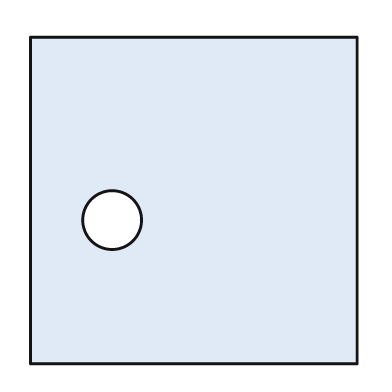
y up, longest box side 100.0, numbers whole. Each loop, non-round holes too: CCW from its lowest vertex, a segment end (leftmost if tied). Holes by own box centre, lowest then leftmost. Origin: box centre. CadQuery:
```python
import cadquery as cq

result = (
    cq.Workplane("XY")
    .moveTo(-50.0, -50.0)
    .lineTo(50.0, -50.0)
    .lineTo(50.0, 50.0)
    .lineTo(-50.0, 50.0)
    .close()
    .moveTo(-25.0, -6.0)
    .circle(9.0)
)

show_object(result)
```